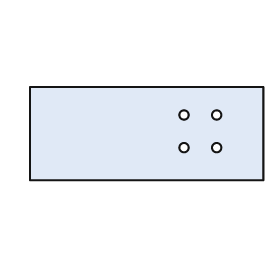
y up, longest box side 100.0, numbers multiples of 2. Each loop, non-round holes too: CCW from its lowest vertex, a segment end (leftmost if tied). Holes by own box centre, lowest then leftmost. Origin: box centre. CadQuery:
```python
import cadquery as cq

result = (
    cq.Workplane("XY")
    .moveTo(-50.0, -20.0)
    .lineTo(50.0, -20.0)
    .lineTo(50.0, 20.0)
    .lineTo(-50.0, 20.0)
    .close()
    .moveTo(16.0, -6.0)
    .circle(2.0)
    .moveTo(30.0, -6.0)
    .circle(2.0)
    .moveTo(16.0, 8.0)
    .circle(2.0)
    .moveTo(30.0, 8.0)
    .circle(2.0)
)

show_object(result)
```